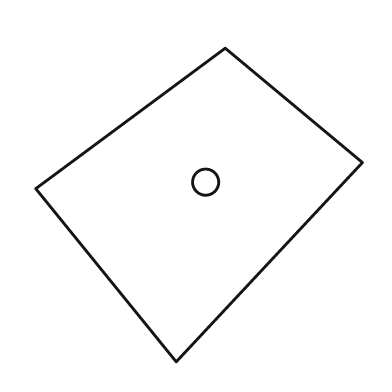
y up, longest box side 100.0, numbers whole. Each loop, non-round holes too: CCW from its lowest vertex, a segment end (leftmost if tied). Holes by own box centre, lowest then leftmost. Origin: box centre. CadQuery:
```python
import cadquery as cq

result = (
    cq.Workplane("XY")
    .moveTo(-7.0, -48.0)
    .lineTo(50.0, 13.0)
    .lineTo(8.0, 48.0)
    .lineTo(-50.0, 5.0)
    .close()
    .moveTo(2.0, 7.0)
    .circle(4.0)
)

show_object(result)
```